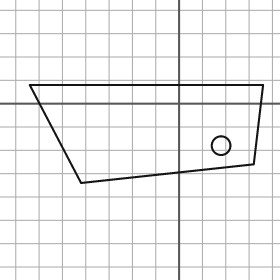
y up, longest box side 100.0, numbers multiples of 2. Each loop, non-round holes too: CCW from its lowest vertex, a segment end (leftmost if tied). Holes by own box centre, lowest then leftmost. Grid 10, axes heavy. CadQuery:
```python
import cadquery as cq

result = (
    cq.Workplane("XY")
    .moveTo(-42.0, -34.0)
    .lineTo(32.0, -26.0)
    .lineTo(36.0, 8.0)
    .lineTo(-64.0, 8.0)
    .close()
    .moveTo(18.0, -18.0)
    .circle(4.0)
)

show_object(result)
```